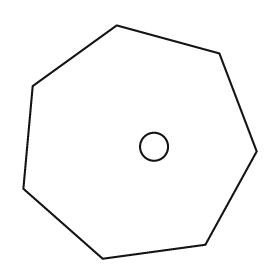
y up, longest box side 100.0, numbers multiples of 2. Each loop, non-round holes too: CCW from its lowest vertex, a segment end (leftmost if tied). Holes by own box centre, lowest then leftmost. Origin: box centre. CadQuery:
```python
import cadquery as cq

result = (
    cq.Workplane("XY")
    .moveTo(-16.0, -50.0)
    .lineTo(28.0, -44.0)
    .lineTo(50.0, -4.0)
    .lineTo(34.0, 38.0)
    .lineTo(-10.0, 50.0)
    .lineTo(-46.0, 24.0)
    .lineTo(-50.0, -20.0)
    .close()
    .moveTo(6.0, -2.0)
    .circle(6.0)
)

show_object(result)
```